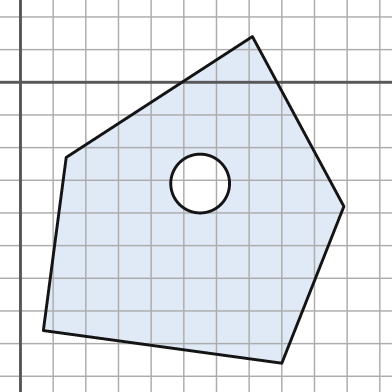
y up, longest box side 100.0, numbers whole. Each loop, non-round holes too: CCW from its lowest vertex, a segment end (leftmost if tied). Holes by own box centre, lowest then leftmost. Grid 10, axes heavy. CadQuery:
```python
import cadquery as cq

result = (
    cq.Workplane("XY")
    .moveTo(80.0, -86.0)
    .lineTo(99.0, -38.0)
    .lineTo(71.0, 14.0)
    .lineTo(14.0, -23.0)
    .lineTo(7.0, -76.0)
    .close()
    .moveTo(55.0, -31.0)
    .circle(9.0)
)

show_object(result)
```